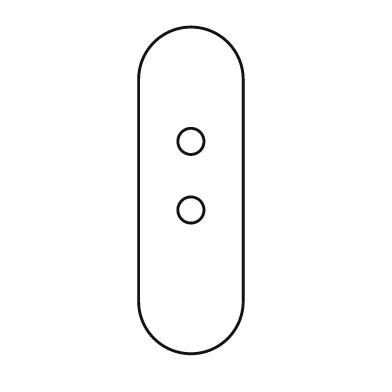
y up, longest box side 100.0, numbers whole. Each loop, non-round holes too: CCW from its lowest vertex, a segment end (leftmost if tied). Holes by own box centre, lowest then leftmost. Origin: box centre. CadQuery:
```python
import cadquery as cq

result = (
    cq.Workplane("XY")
    .moveTo(-16.0, -34.0)
    .threePointArc((0.0, -50.0), (16.0, -34.0))
    .lineTo(16.0, 34.0)
    .threePointArc((0.0, 50.0), (-16.0, 34.0))
    .close()
    .moveTo(0.0, -6.0)
    .circle(4.0)
    .moveTo(0.0, 15.0)
    .circle(4.0)
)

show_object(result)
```